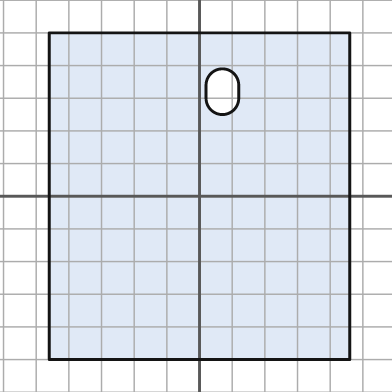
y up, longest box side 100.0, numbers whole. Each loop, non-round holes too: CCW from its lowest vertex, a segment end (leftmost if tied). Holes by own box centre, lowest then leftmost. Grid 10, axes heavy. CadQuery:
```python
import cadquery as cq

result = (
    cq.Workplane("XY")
    .moveTo(-46.0, -50.0)
    .lineTo(46.0, -50.0)
    .lineTo(46.0, 50.0)
    .lineTo(-46.0, 50.0)
    .close()
    .moveTo(2.0, 30.0)
    .threePointArc((7.0, 25.0), (12.0, 30.0))
    .lineTo(12.0, 34.0)
    .threePointArc((7.0, 39.0), (2.0, 34.0))
    .close()
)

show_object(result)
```